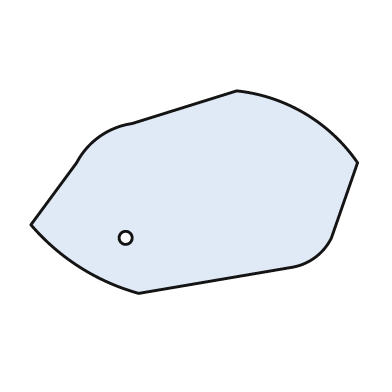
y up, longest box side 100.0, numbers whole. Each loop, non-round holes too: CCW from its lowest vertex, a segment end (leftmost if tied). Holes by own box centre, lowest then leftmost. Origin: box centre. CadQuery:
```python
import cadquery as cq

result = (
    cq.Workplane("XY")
    .moveTo(-17.0, -31.0)
    .lineTo(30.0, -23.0)
    .threePointArc((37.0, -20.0), (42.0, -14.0))
    .lineTo(50.0, 9.0)
    .threePointArc((34.0, 24.0), (13.0, 31.0))
    .lineTo(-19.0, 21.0)
    .threePointArc((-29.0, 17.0), (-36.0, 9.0))
    .lineTo(-50.0, -10.0)
    .threePointArc((-35.0, -23.0), (-17.0, -31.0))
    .close()
    .moveTo(-21.0, -14.0)
    .circle(2.0)
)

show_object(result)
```